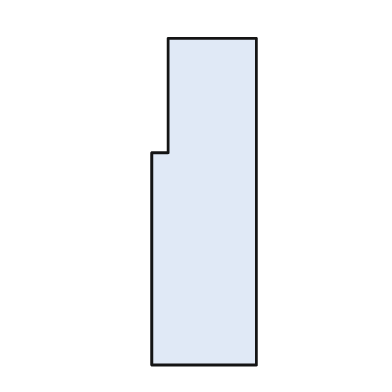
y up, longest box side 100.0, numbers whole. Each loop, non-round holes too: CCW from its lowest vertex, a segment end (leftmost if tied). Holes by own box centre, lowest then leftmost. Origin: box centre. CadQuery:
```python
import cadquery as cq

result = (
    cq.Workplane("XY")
    .moveTo(-16.0, -50.0)
    .lineTo(16.0, -50.0)
    .lineTo(16.0, 50.0)
    .lineTo(-11.0, 50.0)
    .lineTo(-11.0, 15.0)
    .lineTo(-16.0, 15.0)
    .close()
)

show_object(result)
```